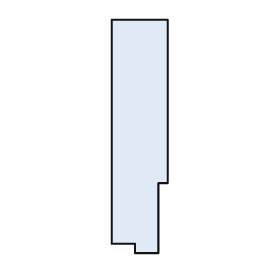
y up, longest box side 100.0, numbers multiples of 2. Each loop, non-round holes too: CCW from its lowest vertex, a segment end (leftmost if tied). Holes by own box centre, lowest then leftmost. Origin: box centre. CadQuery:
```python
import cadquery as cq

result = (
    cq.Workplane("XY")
    .moveTo(-2.0, -50.0)
    .lineTo(8.0, -50.0)
    .lineTo(8.0, -20.0)
    .lineTo(12.0, -20.0)
    .lineTo(12.0, 50.0)
    .lineTo(-12.0, 50.0)
    .lineTo(-12.0, -46.0)
    .lineTo(-2.0, -46.0)
    .close()
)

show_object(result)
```